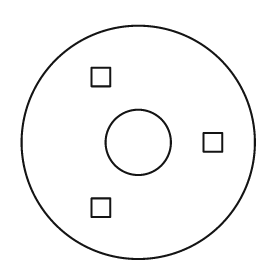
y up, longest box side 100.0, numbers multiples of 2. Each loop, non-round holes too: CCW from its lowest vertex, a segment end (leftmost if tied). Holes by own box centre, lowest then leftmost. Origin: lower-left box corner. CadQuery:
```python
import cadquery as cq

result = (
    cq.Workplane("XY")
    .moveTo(50.0, 50.0)
    .circle(50.0)
    .moveTo(30.0, 18.0)
    .lineTo(38.0, 18.0)
    .lineTo(38.0, 26.0)
    .lineTo(30.0, 26.0)
    .close()
    .moveTo(50.0, 50.0)
    .circle(14.0)
    .moveTo(78.0, 46.0)
    .lineTo(86.0, 46.0)
    .lineTo(86.0, 54.0)
    .lineTo(78.0, 54.0)
    .close()
    .moveTo(30.0, 74.0)
    .lineTo(38.0, 74.0)
    .lineTo(38.0, 82.0)
    .lineTo(30.0, 82.0)
    .close()
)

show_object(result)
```